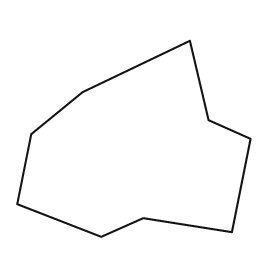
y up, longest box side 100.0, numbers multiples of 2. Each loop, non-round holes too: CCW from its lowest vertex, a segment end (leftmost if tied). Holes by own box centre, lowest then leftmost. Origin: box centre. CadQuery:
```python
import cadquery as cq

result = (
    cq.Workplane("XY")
    .moveTo(-14.0, -42.0)
    .lineTo(4.0, -34.0)
    .lineTo(42.0, -40.0)
    .lineTo(50.0, 0.0)
    .lineTo(32.0, 8.0)
    .lineTo(24.0, 42.0)
    .lineTo(-22.0, 20.0)
    .lineTo(-44.0, 2.0)
    .lineTo(-50.0, -28.0)
    .close()
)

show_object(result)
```